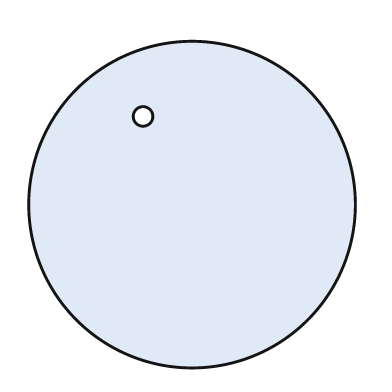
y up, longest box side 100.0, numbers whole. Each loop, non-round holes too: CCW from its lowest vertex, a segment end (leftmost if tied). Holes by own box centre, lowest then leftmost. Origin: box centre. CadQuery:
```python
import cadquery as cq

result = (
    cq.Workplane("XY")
    .moveTo(0.0, 0.0)
    .circle(50.0)
    .moveTo(-15.0, 27.0)
    .circle(3.0)
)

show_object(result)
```